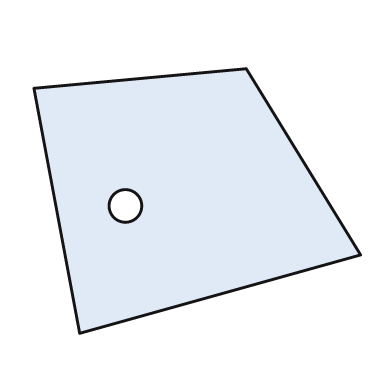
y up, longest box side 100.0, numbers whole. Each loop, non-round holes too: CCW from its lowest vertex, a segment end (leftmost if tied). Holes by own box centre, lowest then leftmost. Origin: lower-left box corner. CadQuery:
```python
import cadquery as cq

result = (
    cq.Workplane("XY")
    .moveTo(14.0, 0.0)
    .lineTo(100.0, 24.0)
    .lineTo(65.0, 81.0)
    .lineTo(0.0, 75.0)
    .close()
    .moveTo(28.0, 39.0)
    .circle(5.0)
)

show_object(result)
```